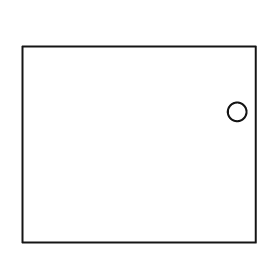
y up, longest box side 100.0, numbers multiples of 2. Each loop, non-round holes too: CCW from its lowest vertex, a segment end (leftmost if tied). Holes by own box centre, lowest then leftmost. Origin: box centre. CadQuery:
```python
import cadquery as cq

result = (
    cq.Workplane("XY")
    .moveTo(-50.0, -42.0)
    .lineTo(50.0, -42.0)
    .lineTo(50.0, 42.0)
    .lineTo(-50.0, 42.0)
    .close()
    .moveTo(42.0, 14.0)
    .circle(4.0)
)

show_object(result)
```